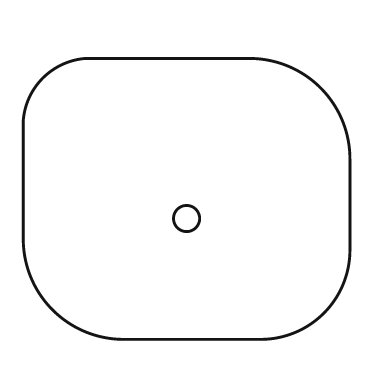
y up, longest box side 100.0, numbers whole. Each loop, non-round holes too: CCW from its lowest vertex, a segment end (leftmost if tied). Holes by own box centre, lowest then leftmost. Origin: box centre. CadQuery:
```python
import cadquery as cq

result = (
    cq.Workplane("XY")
    .moveTo(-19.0, -43.0)
    .lineTo(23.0, -43.0)
    .threePointArc((42.0, -35.0), (50.0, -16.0))
    .lineTo(50.0, 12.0)
    .threePointArc((41.0, 34.0), (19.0, 43.0))
    .lineTo(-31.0, 43.0)
    .threePointArc((-44.0, 37.0), (-50.0, 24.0))
    .lineTo(-50.0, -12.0)
    .threePointArc((-41.0, -34.0), (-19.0, -43.0))
    .close()
    .moveTo(0.0, -6.0)
    .circle(4.0)
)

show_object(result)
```